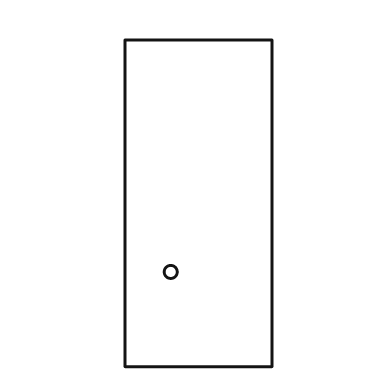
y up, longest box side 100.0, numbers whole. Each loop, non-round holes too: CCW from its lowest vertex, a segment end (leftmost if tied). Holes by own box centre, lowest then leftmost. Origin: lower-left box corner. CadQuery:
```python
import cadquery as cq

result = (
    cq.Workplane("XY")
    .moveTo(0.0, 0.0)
    .lineTo(45.0, 0.0)
    .lineTo(45.0, 100.0)
    .lineTo(0.0, 100.0)
    .close()
    .moveTo(14.0, 29.0)
    .circle(2.0)
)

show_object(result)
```